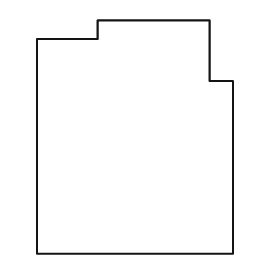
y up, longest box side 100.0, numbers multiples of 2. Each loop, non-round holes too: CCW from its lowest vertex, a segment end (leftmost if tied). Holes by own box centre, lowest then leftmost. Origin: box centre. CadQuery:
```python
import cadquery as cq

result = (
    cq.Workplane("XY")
    .moveTo(-42.0, -50.0)
    .lineTo(42.0, -50.0)
    .lineTo(42.0, 24.0)
    .lineTo(32.0, 24.0)
    .lineTo(32.0, 50.0)
    .lineTo(-16.0, 50.0)
    .lineTo(-16.0, 42.0)
    .lineTo(-42.0, 42.0)
    .close()
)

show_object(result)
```